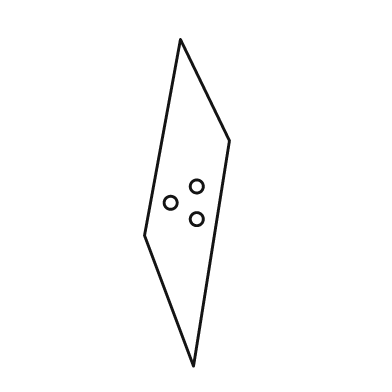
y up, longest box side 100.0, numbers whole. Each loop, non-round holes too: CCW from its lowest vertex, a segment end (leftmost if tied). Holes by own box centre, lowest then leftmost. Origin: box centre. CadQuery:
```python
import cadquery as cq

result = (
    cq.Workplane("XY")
    .moveTo(2.0, -50.0)
    .lineTo(13.0, 19.0)
    .lineTo(-2.0, 50.0)
    .lineTo(-13.0, -10.0)
    .close()
    .moveTo(3.0, -5.0)
    .circle(2.0)
    .moveTo(-5.0, 0.0)
    .circle(2.0)
    .moveTo(3.0, 5.0)
    .circle(2.0)
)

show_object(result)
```